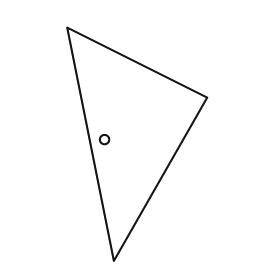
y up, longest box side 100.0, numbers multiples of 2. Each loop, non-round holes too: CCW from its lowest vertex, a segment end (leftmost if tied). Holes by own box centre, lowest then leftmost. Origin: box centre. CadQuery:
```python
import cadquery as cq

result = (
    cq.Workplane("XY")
    .moveTo(-10.0, -50.0)
    .lineTo(30.0, 20.0)
    .lineTo(-30.0, 50.0)
    .close()
    .moveTo(-14.0, 2.0)
    .circle(2.0)
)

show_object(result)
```